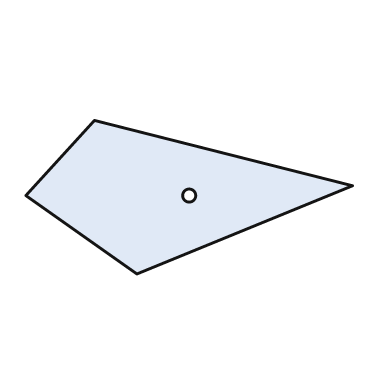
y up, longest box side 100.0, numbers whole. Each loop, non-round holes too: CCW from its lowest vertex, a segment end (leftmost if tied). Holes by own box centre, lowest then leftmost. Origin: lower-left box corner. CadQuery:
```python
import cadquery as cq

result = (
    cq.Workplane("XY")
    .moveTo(34.0, 0.0)
    .lineTo(100.0, 27.0)
    .lineTo(21.0, 47.0)
    .lineTo(0.0, 24.0)
    .close()
    .moveTo(50.0, 24.0)
    .circle(2.0)
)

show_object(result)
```